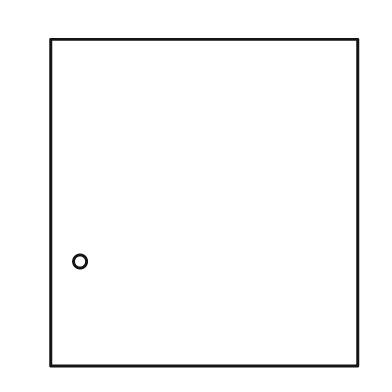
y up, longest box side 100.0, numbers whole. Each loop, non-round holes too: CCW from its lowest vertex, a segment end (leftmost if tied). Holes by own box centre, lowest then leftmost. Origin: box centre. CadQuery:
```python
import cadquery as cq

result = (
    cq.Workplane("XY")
    .moveTo(-47.0, -50.0)
    .lineTo(47.0, -50.0)
    .lineTo(47.0, 50.0)
    .lineTo(-47.0, 50.0)
    .close()
    .moveTo(-38.0, -18.0)
    .circle(2.0)
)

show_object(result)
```